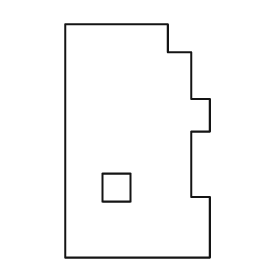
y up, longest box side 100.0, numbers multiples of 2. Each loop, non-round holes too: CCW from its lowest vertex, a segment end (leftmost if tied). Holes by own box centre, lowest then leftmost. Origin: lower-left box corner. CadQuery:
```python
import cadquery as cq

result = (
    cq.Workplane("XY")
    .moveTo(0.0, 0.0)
    .lineTo(62.0, 0.0)
    .lineTo(62.0, 26.0)
    .lineTo(54.0, 26.0)
    .lineTo(54.0, 54.0)
    .lineTo(62.0, 54.0)
    .lineTo(62.0, 68.0)
    .lineTo(54.0, 68.0)
    .lineTo(54.0, 88.0)
    .lineTo(44.0, 88.0)
    .lineTo(44.0, 100.0)
    .lineTo(0.0, 100.0)
    .close()
    .moveTo(16.0, 24.0)
    .lineTo(28.0, 24.0)
    .lineTo(28.0, 36.0)
    .lineTo(16.0, 36.0)
    .close()
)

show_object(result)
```